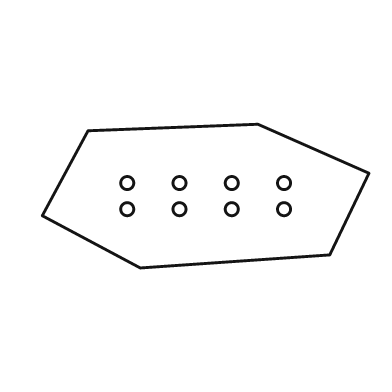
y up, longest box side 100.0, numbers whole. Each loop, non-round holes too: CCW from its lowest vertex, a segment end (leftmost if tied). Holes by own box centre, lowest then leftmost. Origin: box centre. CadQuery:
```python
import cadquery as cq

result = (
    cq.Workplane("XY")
    .moveTo(-20.0, -22.0)
    .lineTo(38.0, -18.0)
    .lineTo(50.0, 7.0)
    .lineTo(16.0, 22.0)
    .lineTo(-36.0, 20.0)
    .lineTo(-50.0, -6.0)
    .close()
    .moveTo(-24.0, -4.0)
    .circle(2.0)
    .moveTo(-8.0, -4.0)
    .circle(2.0)
    .moveTo(8.0, -4.0)
    .circle(2.0)
    .moveTo(24.0, -4.0)
    .circle(2.0)
    .moveTo(-24.0, 4.0)
    .circle(2.0)
    .moveTo(-8.0, 4.0)
    .circle(2.0)
    .moveTo(8.0, 4.0)
    .circle(2.0)
    .moveTo(24.0, 4.0)
    .circle(2.0)
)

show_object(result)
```